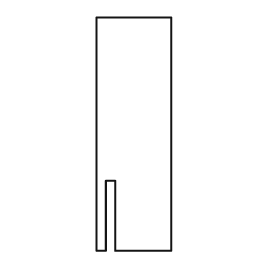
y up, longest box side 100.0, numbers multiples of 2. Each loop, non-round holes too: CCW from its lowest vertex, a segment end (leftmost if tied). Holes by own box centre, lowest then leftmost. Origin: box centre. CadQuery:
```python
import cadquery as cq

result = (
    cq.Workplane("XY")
    .moveTo(-16.0, -50.0)
    .lineTo(-12.0, -50.0)
    .lineTo(-12.0, -20.0)
    .lineTo(-8.0, -20.0)
    .lineTo(-8.0, -50.0)
    .lineTo(16.0, -50.0)
    .lineTo(16.0, 50.0)
    .lineTo(-16.0, 50.0)
    .close()
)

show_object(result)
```